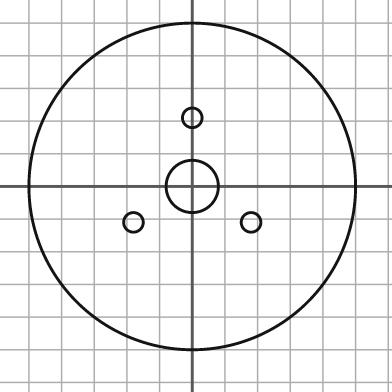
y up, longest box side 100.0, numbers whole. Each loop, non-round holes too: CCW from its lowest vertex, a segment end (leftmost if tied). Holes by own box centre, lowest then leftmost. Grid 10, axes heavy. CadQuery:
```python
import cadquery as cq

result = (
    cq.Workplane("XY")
    .moveTo(0.0, 0.0)
    .circle(50.0)
    .moveTo(-18.0, -11.0)
    .circle(3.0)
    .moveTo(18.0, -11.0)
    .circle(3.0)
    .moveTo(0.0, 0.0)
    .circle(8.0)
    .moveTo(0.0, 21.0)
    .circle(3.0)
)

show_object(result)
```